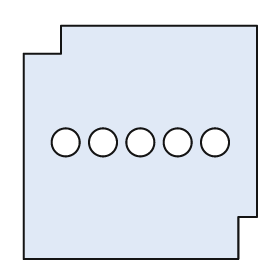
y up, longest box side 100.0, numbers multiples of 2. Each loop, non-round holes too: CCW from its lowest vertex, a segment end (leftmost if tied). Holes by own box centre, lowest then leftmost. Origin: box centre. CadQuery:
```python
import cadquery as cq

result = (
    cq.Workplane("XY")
    .moveTo(-50.0, -50.0)
    .lineTo(42.0, -50.0)
    .lineTo(42.0, -32.0)
    .lineTo(50.0, -32.0)
    .lineTo(50.0, 50.0)
    .lineTo(-34.0, 50.0)
    .lineTo(-34.0, 38.0)
    .lineTo(-50.0, 38.0)
    .close()
    .moveTo(-32.0, 0.0)
    .circle(6.0)
    .moveTo(-16.0, 0.0)
    .circle(6.0)
    .moveTo(0.0, 0.0)
    .circle(6.0)
    .moveTo(16.0, 0.0)
    .circle(6.0)
    .moveTo(32.0, 0.0)
    .circle(6.0)
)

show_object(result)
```